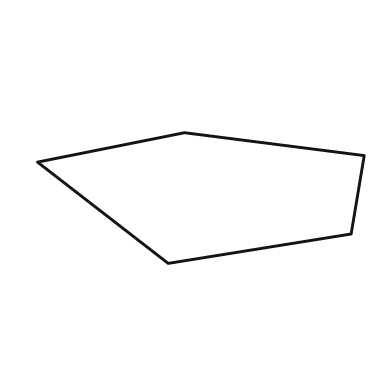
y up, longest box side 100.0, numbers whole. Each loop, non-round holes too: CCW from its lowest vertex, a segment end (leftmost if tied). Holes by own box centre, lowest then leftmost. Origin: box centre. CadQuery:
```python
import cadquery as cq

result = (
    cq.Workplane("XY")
    .moveTo(-10.0, -20.0)
    .lineTo(46.0, -11.0)
    .lineTo(50.0, 13.0)
    .lineTo(-5.0, 20.0)
    .lineTo(-50.0, 11.0)
    .close()
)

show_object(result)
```